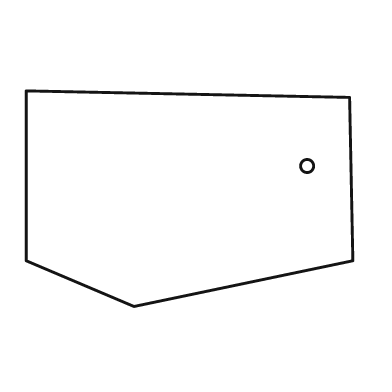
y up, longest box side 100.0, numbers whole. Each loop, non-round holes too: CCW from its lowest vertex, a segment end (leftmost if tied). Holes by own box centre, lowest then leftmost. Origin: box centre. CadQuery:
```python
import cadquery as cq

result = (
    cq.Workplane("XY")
    .moveTo(-17.0, -33.0)
    .lineTo(50.0, -19.0)
    .lineTo(49.0, 31.0)
    .lineTo(-50.0, 33.0)
    .lineTo(-50.0, -19.0)
    .close()
    .moveTo(36.0, 10.0)
    .circle(2.0)
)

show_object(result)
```